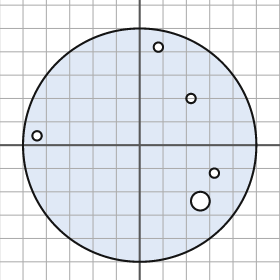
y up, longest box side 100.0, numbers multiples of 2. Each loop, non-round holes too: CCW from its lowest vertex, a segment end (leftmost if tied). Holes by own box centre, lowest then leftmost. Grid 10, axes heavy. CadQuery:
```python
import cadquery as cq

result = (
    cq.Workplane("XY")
    .moveTo(0.0, 0.0)
    .circle(50.0)
    .moveTo(26.0, -24.0)
    .circle(4.0)
    .moveTo(32.0, -12.0)
    .circle(2.0)
    .moveTo(-44.0, 4.0)
    .circle(2.0)
    .moveTo(22.0, 20.0)
    .circle(2.0)
    .moveTo(8.0, 42.0)
    .circle(2.0)
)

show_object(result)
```